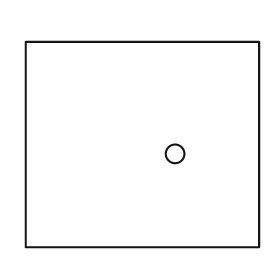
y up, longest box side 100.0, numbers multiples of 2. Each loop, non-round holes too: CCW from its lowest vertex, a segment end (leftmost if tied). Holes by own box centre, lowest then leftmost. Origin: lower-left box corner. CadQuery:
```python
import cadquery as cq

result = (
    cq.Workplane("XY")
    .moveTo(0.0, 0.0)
    .lineTo(100.0, 0.0)
    .lineTo(100.0, 88.0)
    .lineTo(0.0, 88.0)
    .close()
    .moveTo(64.0, 40.0)
    .circle(4.0)
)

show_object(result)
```